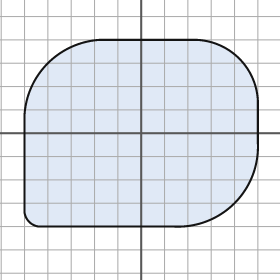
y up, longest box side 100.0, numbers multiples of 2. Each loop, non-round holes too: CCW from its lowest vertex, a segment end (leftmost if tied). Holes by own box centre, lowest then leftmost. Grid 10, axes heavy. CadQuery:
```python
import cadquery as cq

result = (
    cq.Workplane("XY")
    .moveTo(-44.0, -40.0)
    .lineTo(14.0, -40.0)
    .threePointArc((40.0, -30.0), (50.0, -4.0))
    .lineTo(50.0, 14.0)
    .threePointArc((42.0, 32.0), (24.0, 40.0))
    .lineTo(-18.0, 40.0)
    .threePointArc((-40.0, 30.0), (-50.0, 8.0))
    .lineTo(-50.0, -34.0)
    .threePointArc((-48.0, -38.0), (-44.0, -40.0))
    .close()
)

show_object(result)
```